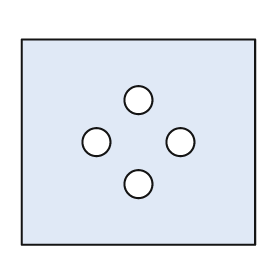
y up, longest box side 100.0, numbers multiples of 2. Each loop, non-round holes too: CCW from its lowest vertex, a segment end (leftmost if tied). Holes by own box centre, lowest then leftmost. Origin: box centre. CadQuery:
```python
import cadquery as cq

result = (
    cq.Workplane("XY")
    .moveTo(-50.0, -44.0)
    .lineTo(50.0, -44.0)
    .lineTo(50.0, 44.0)
    .lineTo(-50.0, 44.0)
    .close()
    .moveTo(0.0, -18.0)
    .circle(6.0)
    .moveTo(-18.0, 0.0)
    .circle(6.0)
    .moveTo(18.0, 0.0)
    .circle(6.0)
    .moveTo(0.0, 18.0)
    .circle(6.0)
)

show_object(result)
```